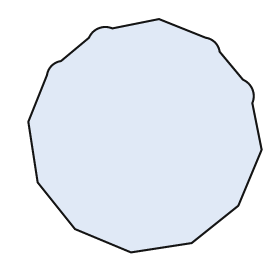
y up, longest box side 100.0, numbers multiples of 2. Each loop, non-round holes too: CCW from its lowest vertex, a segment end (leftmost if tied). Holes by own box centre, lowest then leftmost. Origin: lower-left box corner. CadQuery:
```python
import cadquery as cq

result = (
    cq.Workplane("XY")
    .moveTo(44.0, 0.0)
    .lineTo(70.0, 4.0)
    .lineTo(90.0, 20.0)
    .lineTo(100.0, 44.0)
    .lineTo(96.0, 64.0)
    .threePointArc((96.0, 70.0), (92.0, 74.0))
    .lineTo(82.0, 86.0)
    .threePointArc((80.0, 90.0), (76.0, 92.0))
    .lineTo(56.0, 100.0)
    .lineTo(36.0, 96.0)
    .threePointArc((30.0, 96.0), (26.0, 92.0))
    .lineTo(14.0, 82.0)
    .threePointArc((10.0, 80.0), (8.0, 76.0))
    .lineTo(0.0, 56.0)
    .lineTo(4.0, 30.0)
    .lineTo(20.0, 10.0)
    .close()
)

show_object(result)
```